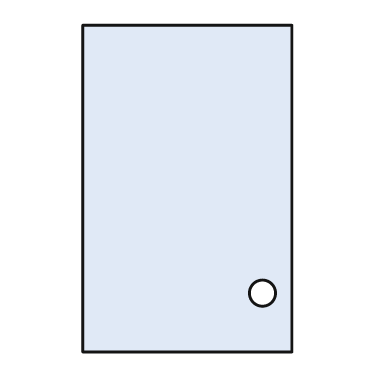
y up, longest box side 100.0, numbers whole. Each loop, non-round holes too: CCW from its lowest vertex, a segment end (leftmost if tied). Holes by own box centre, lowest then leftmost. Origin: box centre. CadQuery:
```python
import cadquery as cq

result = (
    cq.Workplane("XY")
    .moveTo(-32.0, -50.0)
    .lineTo(32.0, -50.0)
    .lineTo(32.0, 50.0)
    .lineTo(-32.0, 50.0)
    .close()
    .moveTo(23.0, -32.0)
    .circle(4.0)
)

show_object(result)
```